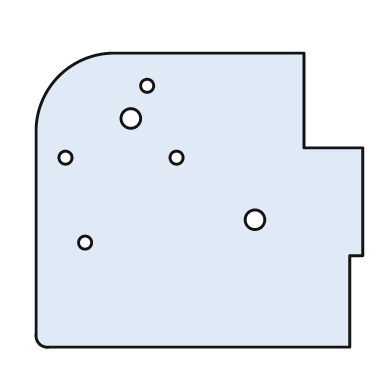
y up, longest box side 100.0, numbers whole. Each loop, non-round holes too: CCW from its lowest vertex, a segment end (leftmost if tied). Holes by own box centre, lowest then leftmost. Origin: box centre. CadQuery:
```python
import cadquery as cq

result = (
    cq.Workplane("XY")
    .moveTo(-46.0, -45.0)
    .lineTo(46.0, -45.0)
    .lineTo(46.0, -17.0)
    .lineTo(50.0, -17.0)
    .lineTo(50.0, 16.0)
    .lineTo(32.0, 16.0)
    .lineTo(32.0, 45.0)
    .lineTo(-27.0, 45.0)
    .threePointArc((-43.0, 38.0), (-50.0, 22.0))
    .lineTo(-50.0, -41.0)
    .threePointArc((-49.0, -44.0), (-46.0, -45.0))
    .close()
    .moveTo(-35.0, -13.0)
    .circle(2.0)
    .moveTo(17.0, -6.0)
    .circle(3.0)
    .moveTo(-41.0, 13.0)
    .circle(2.0)
    .moveTo(-7.0, 13.0)
    .circle(2.0)
    .moveTo(-21.0, 25.0)
    .circle(3.0)
    .moveTo(-16.0, 35.0)
    .circle(2.0)
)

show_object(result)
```